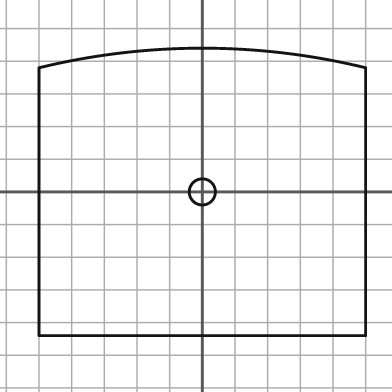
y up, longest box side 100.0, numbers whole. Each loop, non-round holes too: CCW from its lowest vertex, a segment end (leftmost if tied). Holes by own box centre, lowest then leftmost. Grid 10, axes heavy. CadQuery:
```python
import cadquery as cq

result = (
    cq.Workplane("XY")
    .moveTo(-50.0, -44.0)
    .lineTo(50.0, -44.0)
    .lineTo(50.0, 38.0)
    .threePointArc((0.0, 44.0), (-50.0, 38.0))
    .close()
    .moveTo(0.0, 0.0)
    .circle(4.0)
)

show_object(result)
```